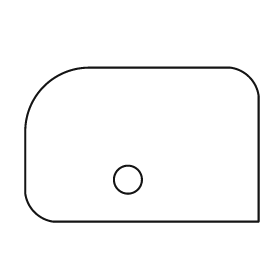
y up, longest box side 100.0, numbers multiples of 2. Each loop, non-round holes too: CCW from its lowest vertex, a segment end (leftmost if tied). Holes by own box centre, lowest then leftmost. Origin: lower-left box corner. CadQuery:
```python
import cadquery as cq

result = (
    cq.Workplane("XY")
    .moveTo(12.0, 0.0)
    .lineTo(100.0, 0.0)
    .lineTo(100.0, 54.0)
    .threePointArc((96.0, 62.0), (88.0, 66.0))
    .lineTo(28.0, 66.0)
    .threePointArc((8.0, 58.0), (0.0, 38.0))
    .lineTo(0.0, 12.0)
    .threePointArc((4.0, 4.0), (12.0, 0.0))
    .close()
    .moveTo(44.0, 18.0)
    .circle(6.0)
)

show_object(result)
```